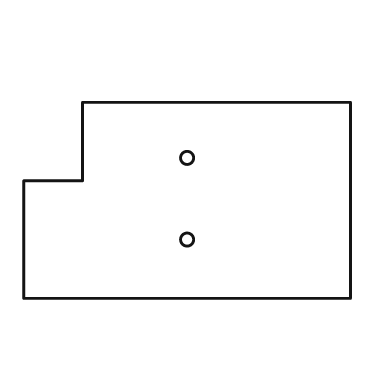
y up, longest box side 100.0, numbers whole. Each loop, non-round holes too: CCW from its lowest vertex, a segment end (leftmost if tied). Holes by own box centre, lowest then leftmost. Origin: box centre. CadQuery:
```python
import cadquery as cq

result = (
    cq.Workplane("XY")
    .moveTo(-50.0, -30.0)
    .lineTo(50.0, -30.0)
    .lineTo(50.0, 30.0)
    .lineTo(-32.0, 30.0)
    .lineTo(-32.0, 6.0)
    .lineTo(-50.0, 6.0)
    .close()
    .moveTo(0.0, -12.0)
    .circle(2.0)
    .moveTo(0.0, 13.0)
    .circle(2.0)
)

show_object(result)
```